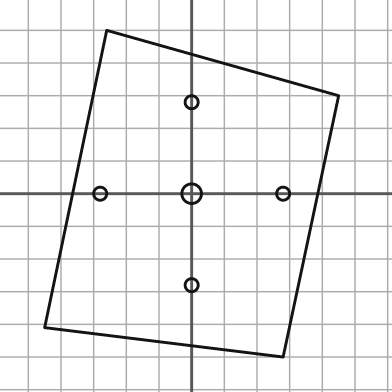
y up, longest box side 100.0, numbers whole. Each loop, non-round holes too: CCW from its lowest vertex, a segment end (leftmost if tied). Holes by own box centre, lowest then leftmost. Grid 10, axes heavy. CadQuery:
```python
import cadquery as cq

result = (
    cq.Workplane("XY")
    .moveTo(28.0, -50.0)
    .lineTo(45.0, 30.0)
    .lineTo(-26.0, 50.0)
    .lineTo(-45.0, -41.0)
    .close()
    .moveTo(0.0, -28.0)
    .circle(2.0)
    .moveTo(-28.0, 0.0)
    .circle(2.0)
    .moveTo(0.0, 0.0)
    .circle(3.0)
    .moveTo(28.0, 0.0)
    .circle(2.0)
    .moveTo(0.0, 28.0)
    .circle(2.0)
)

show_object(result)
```